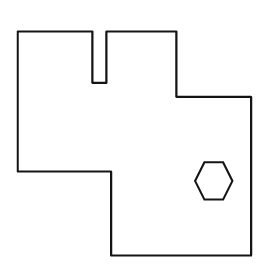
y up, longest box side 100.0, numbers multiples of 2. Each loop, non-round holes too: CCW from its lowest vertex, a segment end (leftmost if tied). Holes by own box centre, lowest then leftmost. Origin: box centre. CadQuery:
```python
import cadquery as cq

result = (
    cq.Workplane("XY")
    .moveTo(-10.0, -48.0)
    .lineTo(50.0, -48.0)
    .lineTo(50.0, 20.0)
    .lineTo(18.0, 20.0)
    .lineTo(18.0, 48.0)
    .lineTo(-12.0, 48.0)
    .lineTo(-12.0, 26.0)
    .lineTo(-18.0, 26.0)
    .lineTo(-18.0, 48.0)
    .lineTo(-50.0, 48.0)
    .lineTo(-50.0, -12.0)
    .lineTo(-10.0, -12.0)
    .close()
    .moveTo(30.0, -24.0)
    .lineTo(38.0, -24.0)
    .lineTo(42.0, -16.0)
    .lineTo(38.0, -8.0)
    .lineTo(30.0, -8.0)
    .lineTo(26.0, -16.0)
    .close()
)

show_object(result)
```